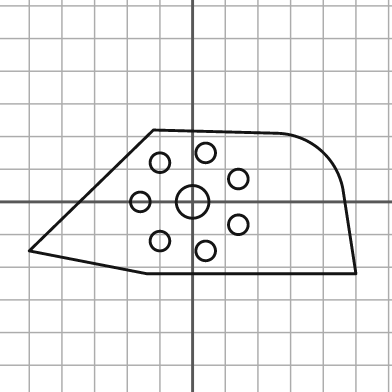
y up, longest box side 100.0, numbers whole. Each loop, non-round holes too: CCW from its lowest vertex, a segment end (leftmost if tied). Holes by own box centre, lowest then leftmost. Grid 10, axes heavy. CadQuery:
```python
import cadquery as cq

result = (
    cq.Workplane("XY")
    .moveTo(-14.0, -22.0)
    .lineTo(50.0, -22.0)
    .lineTo(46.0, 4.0)
    .threePointArc((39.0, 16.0), (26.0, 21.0))
    .lineTo(-12.0, 22.0)
    .lineTo(-50.0, -15.0)
    .close()
    .moveTo(4.0, -15.0)
    .circle(3.0)
    .moveTo(-10.0, -12.0)
    .circle(3.0)
    .moveTo(14.0, -7.0)
    .circle(3.0)
    .moveTo(-16.0, 0.0)
    .circle(3.0)
    .moveTo(0.0, 0.0)
    .circle(5.0)
    .moveTo(14.0, 7.0)
    .circle(3.0)
    .moveTo(-10.0, 12.0)
    .circle(3.0)
    .moveTo(4.0, 15.0)
    .circle(3.0)
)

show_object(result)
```